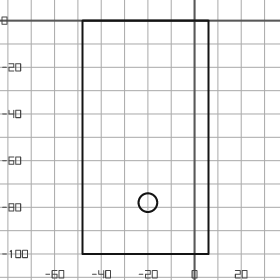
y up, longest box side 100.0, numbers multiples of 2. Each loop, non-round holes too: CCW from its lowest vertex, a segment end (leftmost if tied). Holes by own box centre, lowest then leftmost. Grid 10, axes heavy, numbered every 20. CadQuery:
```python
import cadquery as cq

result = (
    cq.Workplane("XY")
    .moveTo(-48.0, -100.0)
    .lineTo(6.0, -100.0)
    .lineTo(6.0, 0.0)
    .lineTo(-48.0, 0.0)
    .close()
    .moveTo(-20.0, -78.0)
    .circle(4.0)
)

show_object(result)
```